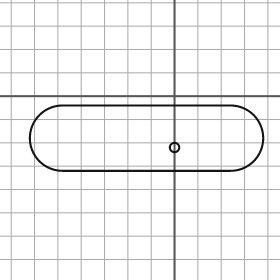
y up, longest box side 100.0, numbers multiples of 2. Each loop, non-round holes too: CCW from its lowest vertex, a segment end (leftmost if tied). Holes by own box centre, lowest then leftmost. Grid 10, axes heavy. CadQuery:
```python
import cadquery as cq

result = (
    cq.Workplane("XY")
    .moveTo(-48.0, -32.0)
    .lineTo(24.0, -32.0)
    .threePointArc((38.0, -18.0), (24.0, -4.0))
    .lineTo(-48.0, -4.0)
    .threePointArc((-62.0, -18.0), (-48.0, -32.0))
    .close()
    .moveTo(0.0, -22.0)
    .circle(2.0)
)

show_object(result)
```